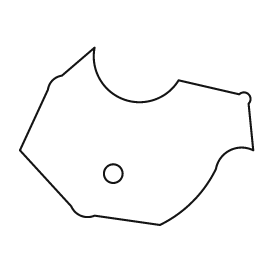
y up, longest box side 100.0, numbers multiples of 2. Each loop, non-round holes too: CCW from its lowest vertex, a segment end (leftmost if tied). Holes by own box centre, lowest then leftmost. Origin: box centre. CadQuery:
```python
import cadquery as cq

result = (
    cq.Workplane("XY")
    .moveTo(10.0, -38.0)
    .threePointArc((24.0, -28.0), (34.0, -14.0))
    .threePointArc((40.0, -6.0), (50.0, -6.0))
    .lineTo(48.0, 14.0)
    .threePointArc((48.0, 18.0), (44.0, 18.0))
    .lineTo(18.0, 24.0)
    .threePointArc((-6.0, 16.0), (-18.0, 38.0))
    .lineTo(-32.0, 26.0)
    .threePointArc((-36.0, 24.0), (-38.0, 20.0))
    .lineTo(-50.0, -6.0)
    .lineTo(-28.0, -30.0)
    .threePointArc((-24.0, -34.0), (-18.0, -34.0))
    .close()
    .moveTo(-10.0, -16.0)
    .circle(4.0)
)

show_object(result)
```